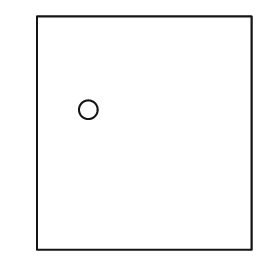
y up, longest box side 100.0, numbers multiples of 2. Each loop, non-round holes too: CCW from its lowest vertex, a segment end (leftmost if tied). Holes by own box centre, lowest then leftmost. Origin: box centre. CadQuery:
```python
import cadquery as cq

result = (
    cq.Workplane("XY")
    .moveTo(-46.0, -50.0)
    .lineTo(46.0, -50.0)
    .lineTo(46.0, 50.0)
    .lineTo(-46.0, 50.0)
    .close()
    .moveTo(-24.0, 10.0)
    .circle(4.0)
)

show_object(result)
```